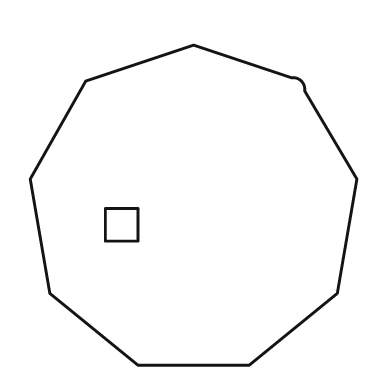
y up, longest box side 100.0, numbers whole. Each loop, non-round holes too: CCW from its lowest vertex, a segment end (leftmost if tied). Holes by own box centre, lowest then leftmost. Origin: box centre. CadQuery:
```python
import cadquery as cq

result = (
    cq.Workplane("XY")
    .moveTo(-17.0, -49.0)
    .lineTo(17.0, -49.0)
    .lineTo(44.0, -27.0)
    .lineTo(50.0, 8.0)
    .lineTo(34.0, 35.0)
    .threePointArc((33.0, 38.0), (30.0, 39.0))
    .lineTo(0.0, 49.0)
    .lineTo(-33.0, 38.0)
    .lineTo(-50.0, 8.0)
    .lineTo(-44.0, -27.0)
    .close()
    .moveTo(-27.0, -11.0)
    .lineTo(-17.0, -11.0)
    .lineTo(-17.0, -1.0)
    .lineTo(-27.0, -1.0)
    .close()
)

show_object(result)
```